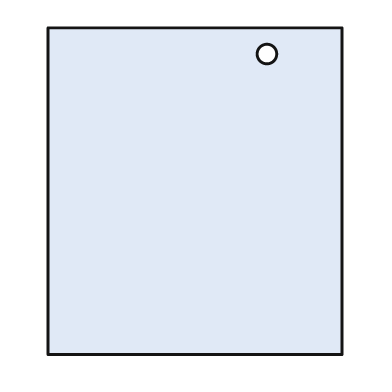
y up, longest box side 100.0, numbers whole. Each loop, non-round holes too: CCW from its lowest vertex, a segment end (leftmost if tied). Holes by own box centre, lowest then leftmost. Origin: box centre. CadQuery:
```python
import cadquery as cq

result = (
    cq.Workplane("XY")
    .moveTo(-45.0, -50.0)
    .lineTo(45.0, -50.0)
    .lineTo(45.0, 50.0)
    .lineTo(-45.0, 50.0)
    .close()
    .moveTo(22.0, 42.0)
    .circle(3.0)
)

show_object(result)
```